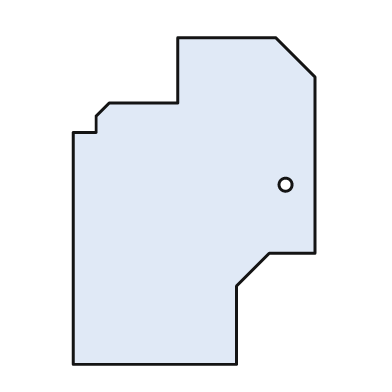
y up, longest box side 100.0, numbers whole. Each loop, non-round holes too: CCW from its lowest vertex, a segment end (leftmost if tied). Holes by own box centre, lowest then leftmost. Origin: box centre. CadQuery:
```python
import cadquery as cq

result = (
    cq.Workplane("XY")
    .moveTo(-37.0, -50.0)
    .lineTo(13.0, -50.0)
    .lineTo(13.0, -26.0)
    .lineTo(23.0, -16.0)
    .lineTo(37.0, -16.0)
    .lineTo(37.0, 38.0)
    .lineTo(25.0, 50.0)
    .lineTo(-5.0, 50.0)
    .lineTo(-5.0, 30.0)
    .lineTo(-26.0, 30.0)
    .lineTo(-30.0, 26.0)
    .lineTo(-30.0, 21.0)
    .lineTo(-37.0, 21.0)
    .close()
    .moveTo(28.0, 5.0)
    .circle(2.0)
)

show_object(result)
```